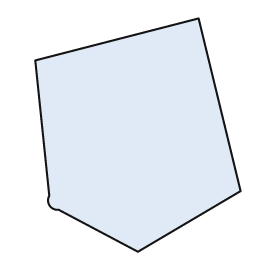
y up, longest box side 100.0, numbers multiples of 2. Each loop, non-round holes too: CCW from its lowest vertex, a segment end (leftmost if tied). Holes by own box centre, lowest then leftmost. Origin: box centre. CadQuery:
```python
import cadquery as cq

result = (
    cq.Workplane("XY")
    .moveTo(0.0, -50.0)
    .lineTo(44.0, -24.0)
    .lineTo(26.0, 50.0)
    .lineTo(-44.0, 32.0)
    .lineTo(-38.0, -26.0)
    .threePointArc((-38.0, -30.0), (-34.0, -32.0))
    .close()
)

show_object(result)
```